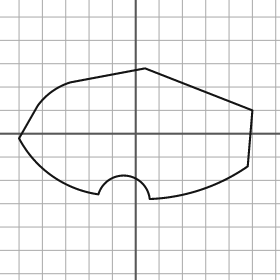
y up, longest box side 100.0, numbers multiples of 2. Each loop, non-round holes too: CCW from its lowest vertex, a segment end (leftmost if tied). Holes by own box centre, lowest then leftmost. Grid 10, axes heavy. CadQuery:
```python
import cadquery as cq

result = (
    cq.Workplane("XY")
    .moveTo(6.0, -28.0)
    .threePointArc((28.0, -24.0), (48.0, -14.0))
    .lineTo(50.0, 10.0)
    .lineTo(4.0, 28.0)
    .lineTo(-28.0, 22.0)
    .threePointArc((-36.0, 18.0), (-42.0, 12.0))
    .lineTo(-50.0, -2.0)
    .threePointArc((-36.0, -18.0), (-16.0, -26.0))
    .threePointArc((-4.0, -18.0), (6.0, -28.0))
    .close()
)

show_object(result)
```